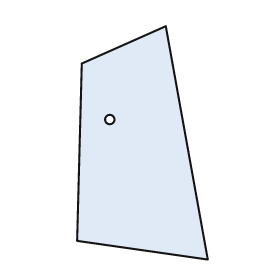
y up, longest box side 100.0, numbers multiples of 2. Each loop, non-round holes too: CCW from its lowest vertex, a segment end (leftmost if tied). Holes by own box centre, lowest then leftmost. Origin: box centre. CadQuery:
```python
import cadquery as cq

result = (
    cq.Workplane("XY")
    .moveTo(28.0, -50.0)
    .lineTo(10.0, 50.0)
    .lineTo(-26.0, 34.0)
    .lineTo(-28.0, -42.0)
    .close()
    .moveTo(-14.0, 10.0)
    .circle(2.0)
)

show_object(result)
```